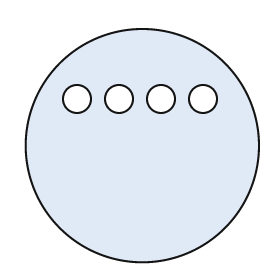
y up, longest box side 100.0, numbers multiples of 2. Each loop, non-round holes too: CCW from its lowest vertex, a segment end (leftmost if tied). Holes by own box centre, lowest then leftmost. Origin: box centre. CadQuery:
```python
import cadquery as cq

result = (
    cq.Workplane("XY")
    .moveTo(0.0, 0.0)
    .circle(50.0)
    .moveTo(-28.0, 20.0)
    .circle(6.0)
    .moveTo(-10.0, 20.0)
    .circle(6.0)
    .moveTo(8.0, 20.0)
    .circle(6.0)
    .moveTo(26.0, 20.0)
    .circle(6.0)
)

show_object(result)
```